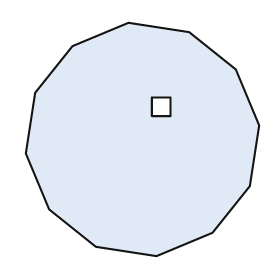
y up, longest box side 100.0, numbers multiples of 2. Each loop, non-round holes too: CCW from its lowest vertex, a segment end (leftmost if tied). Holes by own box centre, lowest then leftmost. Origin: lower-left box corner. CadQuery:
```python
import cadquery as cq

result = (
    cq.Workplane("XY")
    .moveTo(56.0, 0.0)
    .lineTo(80.0, 10.0)
    .lineTo(96.0, 30.0)
    .lineTo(100.0, 56.0)
    .lineTo(90.0, 80.0)
    .lineTo(70.0, 96.0)
    .lineTo(44.0, 100.0)
    .lineTo(20.0, 90.0)
    .lineTo(4.0, 70.0)
    .lineTo(0.0, 44.0)
    .lineTo(10.0, 20.0)
    .lineTo(30.0, 4.0)
    .close()
    .moveTo(54.0, 60.0)
    .lineTo(62.0, 60.0)
    .lineTo(62.0, 68.0)
    .lineTo(54.0, 68.0)
    .close()
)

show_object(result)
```